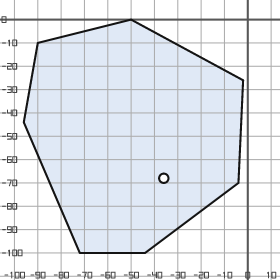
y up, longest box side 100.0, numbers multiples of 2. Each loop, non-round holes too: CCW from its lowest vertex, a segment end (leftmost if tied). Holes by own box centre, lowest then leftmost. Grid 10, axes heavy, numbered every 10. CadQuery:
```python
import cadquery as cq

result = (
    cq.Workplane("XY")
    .moveTo(-72.0, -100.0)
    .lineTo(-44.0, -100.0)
    .lineTo(-4.0, -70.0)
    .lineTo(-2.0, -26.0)
    .lineTo(-50.0, 0.0)
    .lineTo(-90.0, -10.0)
    .lineTo(-96.0, -44.0)
    .close()
    .moveTo(-36.0, -68.0)
    .circle(2.0)
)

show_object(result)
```